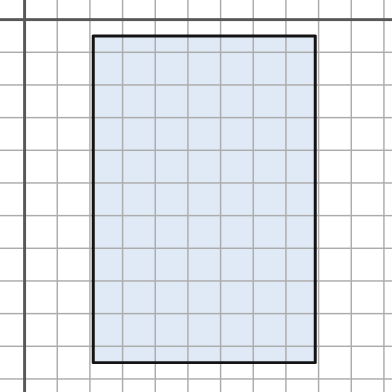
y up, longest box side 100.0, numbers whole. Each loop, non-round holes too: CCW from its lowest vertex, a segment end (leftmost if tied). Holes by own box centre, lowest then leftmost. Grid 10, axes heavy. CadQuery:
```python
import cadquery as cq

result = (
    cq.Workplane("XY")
    .moveTo(21.0, -105.0)
    .lineTo(89.0, -105.0)
    .lineTo(89.0, -5.0)
    .lineTo(21.0, -5.0)
    .close()
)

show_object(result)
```